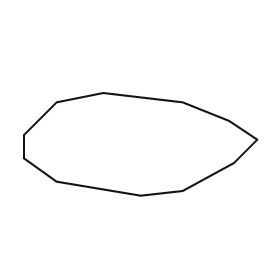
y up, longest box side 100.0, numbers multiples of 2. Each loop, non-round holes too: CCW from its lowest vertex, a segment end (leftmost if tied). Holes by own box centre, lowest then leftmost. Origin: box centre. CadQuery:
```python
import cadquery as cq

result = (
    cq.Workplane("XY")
    .moveTo(0.0, -22.0)
    .lineTo(18.0, -20.0)
    .lineTo(40.0, -8.0)
    .lineTo(50.0, 2.0)
    .lineTo(38.0, 10.0)
    .lineTo(18.0, 18.0)
    .lineTo(-16.0, 22.0)
    .lineTo(-36.0, 18.0)
    .lineTo(-50.0, 4.0)
    .lineTo(-50.0, -6.0)
    .lineTo(-36.0, -16.0)
    .close()
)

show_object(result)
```